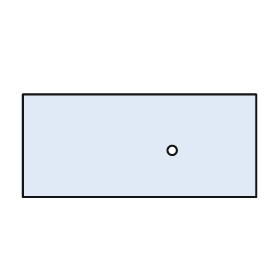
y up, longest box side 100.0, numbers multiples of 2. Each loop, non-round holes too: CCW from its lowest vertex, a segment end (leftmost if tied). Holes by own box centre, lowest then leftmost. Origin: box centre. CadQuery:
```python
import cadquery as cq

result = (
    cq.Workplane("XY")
    .moveTo(-50.0, -22.0)
    .lineTo(50.0, -22.0)
    .lineTo(50.0, 22.0)
    .lineTo(-50.0, 22.0)
    .close()
    .moveTo(14.0, -2.0)
    .circle(2.0)
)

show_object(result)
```